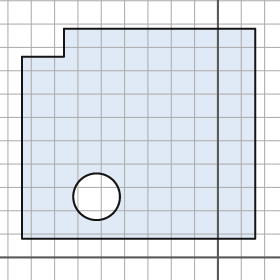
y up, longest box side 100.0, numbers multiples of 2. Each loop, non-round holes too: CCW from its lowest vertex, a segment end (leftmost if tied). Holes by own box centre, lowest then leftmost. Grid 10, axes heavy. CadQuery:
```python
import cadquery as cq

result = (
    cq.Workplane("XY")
    .moveTo(-84.0, 8.0)
    .lineTo(16.0, 8.0)
    .lineTo(16.0, 98.0)
    .lineTo(-66.0, 98.0)
    .lineTo(-66.0, 86.0)
    .lineTo(-84.0, 86.0)
    .close()
    .moveTo(-52.0, 26.0)
    .circle(10.0)
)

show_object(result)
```